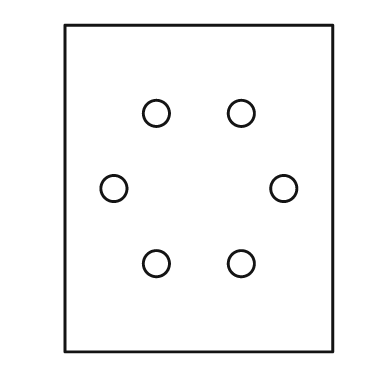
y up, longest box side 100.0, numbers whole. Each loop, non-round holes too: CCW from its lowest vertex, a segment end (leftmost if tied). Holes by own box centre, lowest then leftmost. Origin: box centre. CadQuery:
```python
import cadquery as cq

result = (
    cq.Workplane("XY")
    .moveTo(-41.0, -50.0)
    .lineTo(41.0, -50.0)
    .lineTo(41.0, 50.0)
    .lineTo(-41.0, 50.0)
    .close()
    .moveTo(-13.0, -23.0)
    .circle(4.0)
    .moveTo(13.0, -23.0)
    .circle(4.0)
    .moveTo(-26.0, 0.0)
    .circle(4.0)
    .moveTo(26.0, 0.0)
    .circle(4.0)
    .moveTo(-13.0, 23.0)
    .circle(4.0)
    .moveTo(13.0, 23.0)
    .circle(4.0)
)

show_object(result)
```